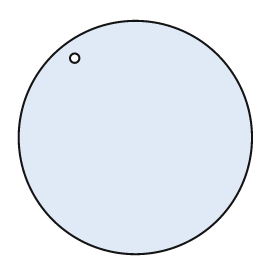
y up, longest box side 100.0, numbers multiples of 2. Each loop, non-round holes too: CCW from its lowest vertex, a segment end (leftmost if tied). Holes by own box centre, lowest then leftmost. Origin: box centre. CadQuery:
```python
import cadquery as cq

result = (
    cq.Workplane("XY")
    .moveTo(0.0, 0.0)
    .circle(50.0)
    .moveTo(-26.0, 34.0)
    .circle(2.0)
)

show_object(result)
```